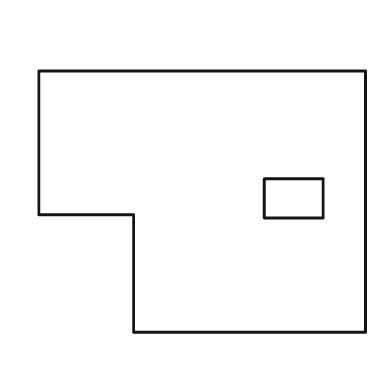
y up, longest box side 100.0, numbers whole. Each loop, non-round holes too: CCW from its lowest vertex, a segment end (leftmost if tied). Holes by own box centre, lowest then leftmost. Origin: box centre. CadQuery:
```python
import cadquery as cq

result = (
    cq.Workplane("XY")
    .moveTo(-21.0, -40.0)
    .lineTo(50.0, -40.0)
    .lineTo(50.0, 40.0)
    .lineTo(-50.0, 40.0)
    .lineTo(-50.0, -4.0)
    .lineTo(-21.0, -4.0)
    .close()
    .moveTo(19.0, -5.0)
    .lineTo(37.0, -5.0)
    .lineTo(37.0, 7.0)
    .lineTo(19.0, 7.0)
    .close()
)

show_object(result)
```